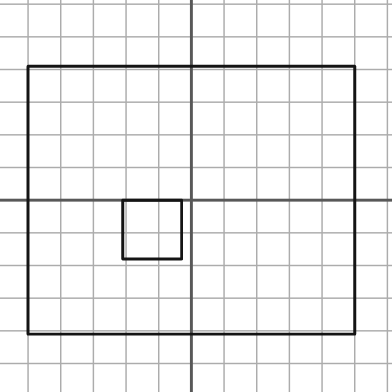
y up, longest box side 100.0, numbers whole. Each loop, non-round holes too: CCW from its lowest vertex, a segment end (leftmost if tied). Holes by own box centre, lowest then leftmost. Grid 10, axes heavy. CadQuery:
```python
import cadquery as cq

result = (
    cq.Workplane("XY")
    .moveTo(-50.0, -41.0)
    .lineTo(50.0, -41.0)
    .lineTo(50.0, 41.0)
    .lineTo(-50.0, 41.0)
    .close()
    .moveTo(-21.0, -18.0)
    .lineTo(-3.0, -18.0)
    .lineTo(-3.0, 0.0)
    .lineTo(-21.0, 0.0)
    .close()
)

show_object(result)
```